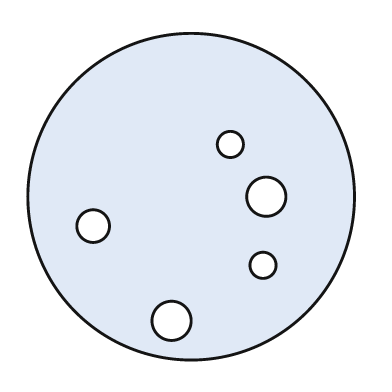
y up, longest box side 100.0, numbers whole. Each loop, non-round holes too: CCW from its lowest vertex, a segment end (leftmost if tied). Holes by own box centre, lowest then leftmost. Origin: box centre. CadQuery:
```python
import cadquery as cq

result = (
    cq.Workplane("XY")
    .moveTo(0.0, 0.0)
    .circle(50.0)
    .moveTo(-6.0, -38.0)
    .circle(6.0)
    .moveTo(22.0, -21.0)
    .circle(4.0)
    .moveTo(-30.0, -9.0)
    .circle(5.0)
    .moveTo(23.0, 0.0)
    .circle(6.0)
    .moveTo(12.0, 16.0)
    .circle(4.0)
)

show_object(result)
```